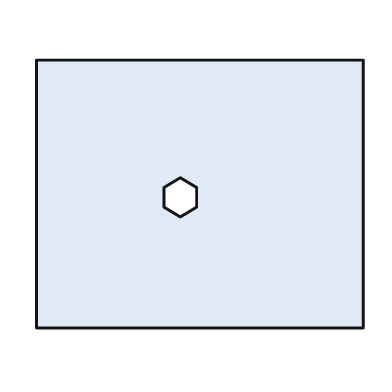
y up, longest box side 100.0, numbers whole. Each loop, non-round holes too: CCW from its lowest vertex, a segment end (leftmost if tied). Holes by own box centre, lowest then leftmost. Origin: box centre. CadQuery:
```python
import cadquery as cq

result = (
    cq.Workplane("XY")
    .moveTo(-50.0, -41.0)
    .lineTo(50.0, -41.0)
    .lineTo(50.0, 41.0)
    .lineTo(-50.0, 41.0)
    .close()
    .moveTo(-6.0, -7.0)
    .lineTo(-1.0, -4.0)
    .lineTo(-1.0, 2.0)
    .lineTo(-6.0, 5.0)
    .lineTo(-11.0, 2.0)
    .lineTo(-11.0, -4.0)
    .close()
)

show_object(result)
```